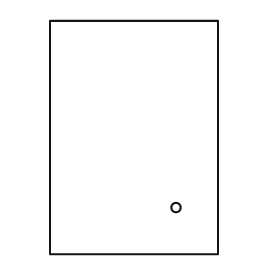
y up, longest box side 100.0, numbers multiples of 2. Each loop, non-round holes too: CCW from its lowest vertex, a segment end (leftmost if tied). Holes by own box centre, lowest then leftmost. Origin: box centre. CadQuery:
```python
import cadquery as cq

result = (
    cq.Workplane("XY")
    .moveTo(-36.0, -50.0)
    .lineTo(36.0, -50.0)
    .lineTo(36.0, 50.0)
    .lineTo(-36.0, 50.0)
    .close()
    .moveTo(18.0, -30.0)
    .circle(2.0)
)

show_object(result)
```